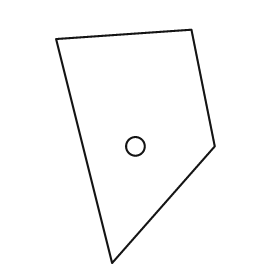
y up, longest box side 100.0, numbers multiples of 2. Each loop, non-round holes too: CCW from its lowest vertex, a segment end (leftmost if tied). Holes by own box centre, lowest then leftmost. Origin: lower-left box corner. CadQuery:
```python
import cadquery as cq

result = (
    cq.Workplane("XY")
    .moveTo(24.0, 0.0)
    .lineTo(68.0, 50.0)
    .lineTo(58.0, 100.0)
    .lineTo(0.0, 96.0)
    .close()
    .moveTo(34.0, 50.0)
    .circle(4.0)
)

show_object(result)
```